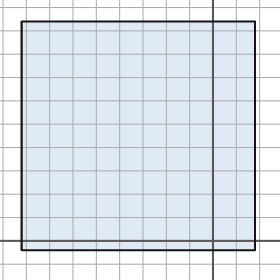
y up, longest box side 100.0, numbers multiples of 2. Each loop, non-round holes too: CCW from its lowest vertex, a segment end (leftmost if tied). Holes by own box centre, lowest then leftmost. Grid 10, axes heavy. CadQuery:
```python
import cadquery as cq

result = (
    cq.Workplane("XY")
    .moveTo(-82.0, -4.0)
    .lineTo(18.0, -4.0)
    .lineTo(18.0, 94.0)
    .lineTo(-82.0, 94.0)
    .close()
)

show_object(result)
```